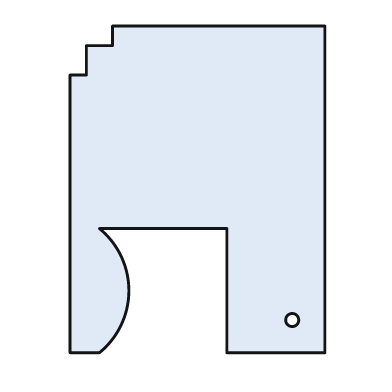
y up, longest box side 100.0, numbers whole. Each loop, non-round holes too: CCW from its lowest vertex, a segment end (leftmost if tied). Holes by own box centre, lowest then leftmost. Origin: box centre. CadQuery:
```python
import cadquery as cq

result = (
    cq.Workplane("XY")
    .moveTo(-39.0, -50.0)
    .lineTo(-30.0, -50.0)
    .threePointArc((-21.0, -31.0), (-30.0, -12.0))
    .lineTo(9.0, -12.0)
    .lineTo(9.0, -50.0)
    .lineTo(39.0, -50.0)
    .lineTo(39.0, 50.0)
    .lineTo(-26.0, 50.0)
    .lineTo(-26.0, 44.0)
    .lineTo(-34.0, 44.0)
    .lineTo(-34.0, 35.0)
    .lineTo(-39.0, 35.0)
    .close()
    .moveTo(29.0, -40.0)
    .circle(2.0)
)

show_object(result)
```